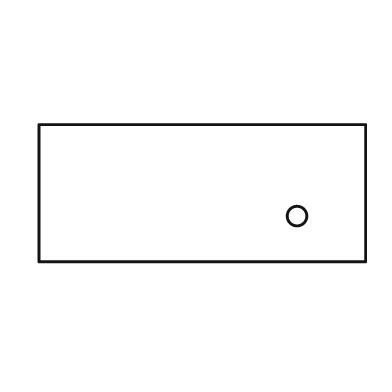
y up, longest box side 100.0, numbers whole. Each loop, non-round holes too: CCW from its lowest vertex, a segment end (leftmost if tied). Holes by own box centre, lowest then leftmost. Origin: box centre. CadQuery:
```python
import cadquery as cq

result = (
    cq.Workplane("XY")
    .moveTo(-50.0, -21.0)
    .lineTo(50.0, -21.0)
    .lineTo(50.0, 21.0)
    .lineTo(-50.0, 21.0)
    .close()
    .moveTo(29.0, -7.0)
    .circle(3.0)
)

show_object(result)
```